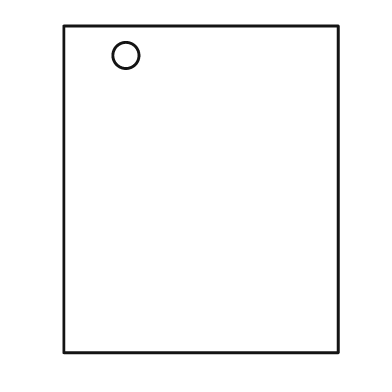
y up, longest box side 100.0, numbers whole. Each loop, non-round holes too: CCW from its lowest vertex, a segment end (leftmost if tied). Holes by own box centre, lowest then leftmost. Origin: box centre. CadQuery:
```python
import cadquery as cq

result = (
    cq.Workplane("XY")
    .moveTo(-42.0, -50.0)
    .lineTo(42.0, -50.0)
    .lineTo(42.0, 50.0)
    .lineTo(-42.0, 50.0)
    .close()
    .moveTo(-23.0, 41.0)
    .circle(4.0)
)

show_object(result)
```